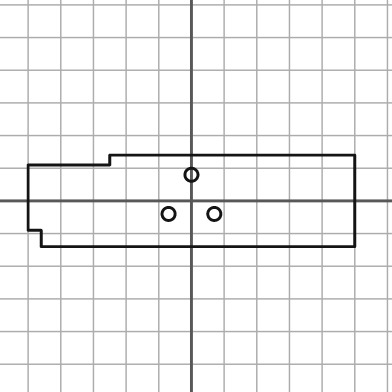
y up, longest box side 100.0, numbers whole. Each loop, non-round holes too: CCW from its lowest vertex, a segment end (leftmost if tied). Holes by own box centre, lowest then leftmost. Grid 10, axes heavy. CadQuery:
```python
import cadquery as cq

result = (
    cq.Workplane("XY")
    .moveTo(-46.0, -14.0)
    .lineTo(50.0, -14.0)
    .lineTo(50.0, 14.0)
    .lineTo(-25.0, 14.0)
    .lineTo(-25.0, 11.0)
    .lineTo(-50.0, 11.0)
    .lineTo(-50.0, -9.0)
    .lineTo(-46.0, -9.0)
    .close()
    .moveTo(-7.0, -4.0)
    .circle(2.0)
    .moveTo(7.0, -4.0)
    .circle(2.0)
    .moveTo(0.0, 8.0)
    .circle(2.0)
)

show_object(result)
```